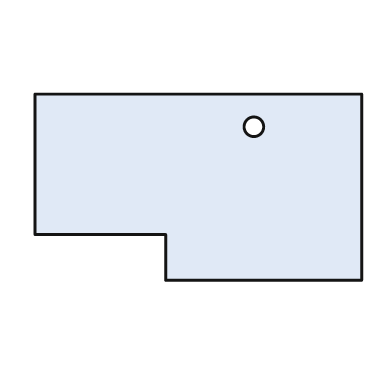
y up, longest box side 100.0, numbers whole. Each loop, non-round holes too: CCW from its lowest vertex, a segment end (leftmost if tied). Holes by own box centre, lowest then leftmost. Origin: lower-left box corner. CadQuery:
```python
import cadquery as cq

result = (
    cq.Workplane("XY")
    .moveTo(40.0, 0.0)
    .lineTo(100.0, 0.0)
    .lineTo(100.0, 57.0)
    .lineTo(0.0, 57.0)
    .lineTo(0.0, 14.0)
    .lineTo(40.0, 14.0)
    .close()
    .moveTo(67.0, 47.0)
    .circle(3.0)
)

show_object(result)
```